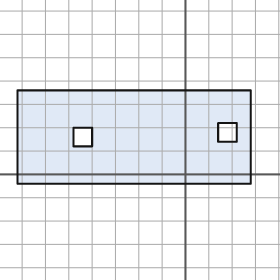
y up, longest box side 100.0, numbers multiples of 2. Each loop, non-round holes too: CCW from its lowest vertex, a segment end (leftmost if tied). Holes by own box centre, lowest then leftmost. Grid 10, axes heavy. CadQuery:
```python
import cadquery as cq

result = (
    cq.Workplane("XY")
    .moveTo(-72.0, -4.0)
    .lineTo(28.0, -4.0)
    .lineTo(28.0, 36.0)
    .lineTo(-72.0, 36.0)
    .close()
    .moveTo(-48.0, 12.0)
    .lineTo(-40.0, 12.0)
    .lineTo(-40.0, 20.0)
    .lineTo(-48.0, 20.0)
    .close()
    .moveTo(14.0, 14.0)
    .lineTo(22.0, 14.0)
    .lineTo(22.0, 22.0)
    .lineTo(14.0, 22.0)
    .close()
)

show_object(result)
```